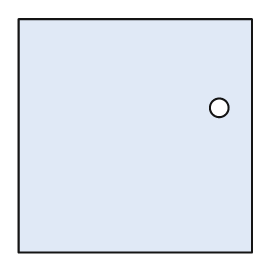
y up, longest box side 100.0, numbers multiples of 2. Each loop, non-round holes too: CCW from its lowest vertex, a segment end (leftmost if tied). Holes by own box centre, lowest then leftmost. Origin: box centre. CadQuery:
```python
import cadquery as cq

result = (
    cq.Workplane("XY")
    .moveTo(-50.0, -50.0)
    .lineTo(50.0, -50.0)
    .lineTo(50.0, 50.0)
    .lineTo(-50.0, 50.0)
    .close()
    .moveTo(36.0, 12.0)
    .circle(4.0)
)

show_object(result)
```